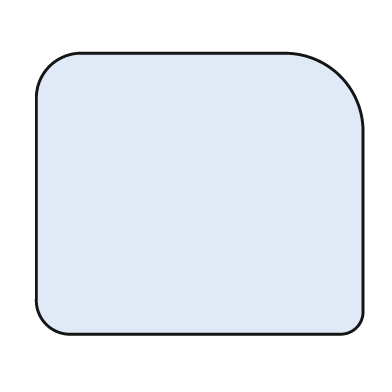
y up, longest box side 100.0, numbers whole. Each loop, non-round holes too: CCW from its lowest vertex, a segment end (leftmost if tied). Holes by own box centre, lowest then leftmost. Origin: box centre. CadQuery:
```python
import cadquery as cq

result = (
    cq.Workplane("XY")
    .moveTo(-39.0, -43.0)
    .lineTo(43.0, -43.0)
    .threePointArc((48.0, -41.0), (50.0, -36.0))
    .lineTo(50.0, 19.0)
    .threePointArc((43.0, 36.0), (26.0, 43.0))
    .lineTo(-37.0, 43.0)
    .threePointArc((-46.0, 39.0), (-50.0, 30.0))
    .lineTo(-50.0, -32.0)
    .threePointArc((-47.0, -40.0), (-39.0, -43.0))
    .close()
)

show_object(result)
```